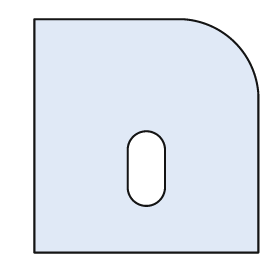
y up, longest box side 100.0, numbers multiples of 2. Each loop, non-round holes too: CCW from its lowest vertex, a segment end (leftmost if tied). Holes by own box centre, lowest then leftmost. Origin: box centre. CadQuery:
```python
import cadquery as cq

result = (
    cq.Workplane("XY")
    .moveTo(-48.0, -50.0)
    .lineTo(48.0, -50.0)
    .lineTo(48.0, 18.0)
    .threePointArc((38.0, 40.0), (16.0, 50.0))
    .lineTo(-48.0, 50.0)
    .close()
    .moveTo(-8.0, -22.0)
    .threePointArc((0.0, -30.0), (8.0, -22.0))
    .lineTo(8.0, -6.0)
    .threePointArc((0.0, 2.0), (-8.0, -6.0))
    .close()
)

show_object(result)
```